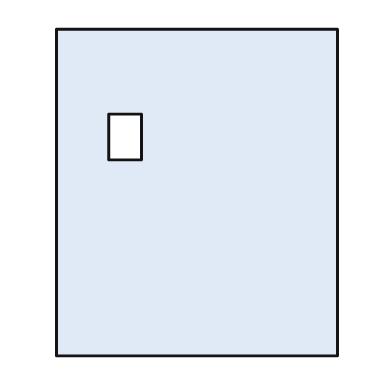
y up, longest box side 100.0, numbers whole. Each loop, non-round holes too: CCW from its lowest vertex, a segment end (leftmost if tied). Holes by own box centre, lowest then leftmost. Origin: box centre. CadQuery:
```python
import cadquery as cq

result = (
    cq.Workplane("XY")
    .moveTo(-43.0, -50.0)
    .lineTo(43.0, -50.0)
    .lineTo(43.0, 50.0)
    .lineTo(-43.0, 50.0)
    .close()
    .moveTo(-27.0, 10.0)
    .lineTo(-17.0, 10.0)
    .lineTo(-17.0, 24.0)
    .lineTo(-27.0, 24.0)
    .close()
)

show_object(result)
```